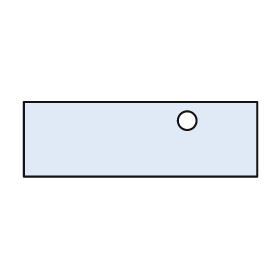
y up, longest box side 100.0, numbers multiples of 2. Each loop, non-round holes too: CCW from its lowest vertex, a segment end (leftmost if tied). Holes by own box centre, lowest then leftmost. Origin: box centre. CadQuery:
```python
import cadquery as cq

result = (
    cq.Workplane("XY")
    .moveTo(-50.0, -16.0)
    .lineTo(50.0, -16.0)
    .lineTo(50.0, 16.0)
    .lineTo(-50.0, 16.0)
    .close()
    .moveTo(20.0, 8.0)
    .circle(4.0)
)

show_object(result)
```